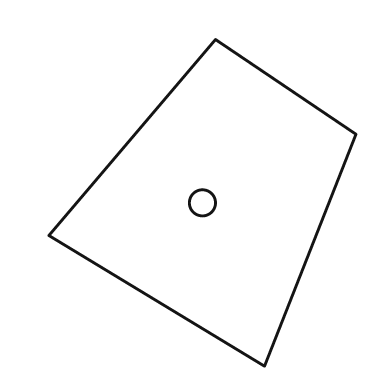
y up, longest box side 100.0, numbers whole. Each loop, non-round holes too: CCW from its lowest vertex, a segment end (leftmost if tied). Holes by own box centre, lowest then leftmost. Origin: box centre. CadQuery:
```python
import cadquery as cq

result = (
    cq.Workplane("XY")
    .moveTo(19.0, -50.0)
    .lineTo(47.0, 21.0)
    .lineTo(4.0, 50.0)
    .lineTo(-47.0, -10.0)
    .close()
    .moveTo(0.0, 0.0)
    .circle(4.0)
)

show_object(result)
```